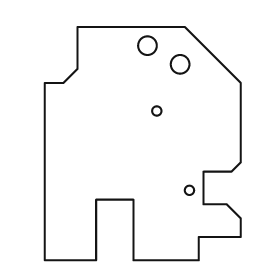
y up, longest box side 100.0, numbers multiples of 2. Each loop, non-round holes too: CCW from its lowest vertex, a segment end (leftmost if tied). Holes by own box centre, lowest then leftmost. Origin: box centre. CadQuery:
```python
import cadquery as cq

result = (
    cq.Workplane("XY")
    .moveTo(-42.0, -50.0)
    .lineTo(-20.0, -50.0)
    .lineTo(-20.0, -24.0)
    .lineTo(-4.0, -24.0)
    .lineTo(-4.0, -50.0)
    .lineTo(24.0, -50.0)
    .lineTo(24.0, -40.0)
    .lineTo(42.0, -40.0)
    .lineTo(42.0, -32.0)
    .lineTo(36.0, -26.0)
    .lineTo(26.0, -26.0)
    .lineTo(26.0, -12.0)
    .lineTo(38.0, -12.0)
    .lineTo(42.0, -8.0)
    .lineTo(42.0, 26.0)
    .lineTo(18.0, 50.0)
    .lineTo(-28.0, 50.0)
    .lineTo(-28.0, 32.0)
    .lineTo(-34.0, 26.0)
    .lineTo(-42.0, 26.0)
    .close()
    .moveTo(20.0, -20.0)
    .circle(2.0)
    .moveTo(6.0, 14.0)
    .circle(2.0)
    .moveTo(16.0, 34.0)
    .circle(4.0)
    .moveTo(2.0, 42.0)
    .circle(4.0)
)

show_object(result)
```